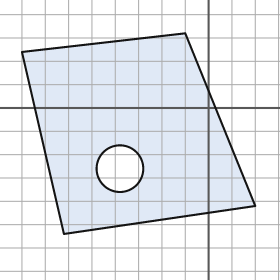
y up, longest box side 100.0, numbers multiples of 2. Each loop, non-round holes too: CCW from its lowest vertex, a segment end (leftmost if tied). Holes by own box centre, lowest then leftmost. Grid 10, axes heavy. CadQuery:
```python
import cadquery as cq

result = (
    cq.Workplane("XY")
    .moveTo(-62.0, -54.0)
    .lineTo(20.0, -42.0)
    .lineTo(-10.0, 32.0)
    .lineTo(-80.0, 24.0)
    .close()
    .moveTo(-38.0, -26.0)
    .circle(10.0)
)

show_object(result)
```